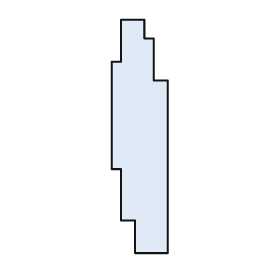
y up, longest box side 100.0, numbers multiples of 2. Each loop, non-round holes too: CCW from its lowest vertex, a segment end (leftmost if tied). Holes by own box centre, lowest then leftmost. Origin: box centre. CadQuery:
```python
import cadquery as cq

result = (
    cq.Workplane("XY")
    .moveTo(-2.0, -50.0)
    .lineTo(12.0, -50.0)
    .lineTo(12.0, 24.0)
    .lineTo(6.0, 24.0)
    .lineTo(6.0, 42.0)
    .lineTo(2.0, 42.0)
    .lineTo(2.0, 50.0)
    .lineTo(-8.0, 50.0)
    .lineTo(-8.0, 32.0)
    .lineTo(-12.0, 32.0)
    .lineTo(-12.0, -14.0)
    .lineTo(-8.0, -14.0)
    .lineTo(-8.0, -36.0)
    .lineTo(-2.0, -36.0)
    .close()
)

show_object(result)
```